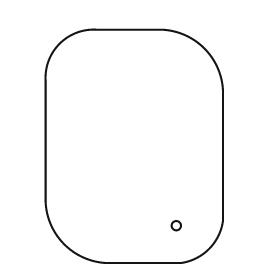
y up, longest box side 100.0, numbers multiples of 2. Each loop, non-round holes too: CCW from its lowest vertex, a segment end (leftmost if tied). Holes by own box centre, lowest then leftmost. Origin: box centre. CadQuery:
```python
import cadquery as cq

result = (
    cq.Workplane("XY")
    .moveTo(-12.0, -50.0)
    .lineTo(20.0, -50.0)
    .threePointArc((32.0, -44.0), (38.0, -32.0))
    .lineTo(38.0, 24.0)
    .threePointArc((30.0, 42.0), (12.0, 50.0))
    .lineTo(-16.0, 50.0)
    .threePointArc((-32.0, 44.0), (-38.0, 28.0))
    .lineTo(-38.0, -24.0)
    .threePointArc((-30.0, -42.0), (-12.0, -50.0))
    .close()
    .moveTo(18.0, -34.0)
    .circle(2.0)
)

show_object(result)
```